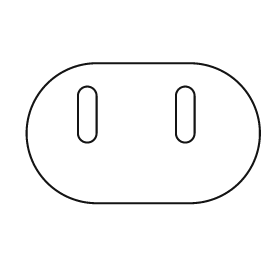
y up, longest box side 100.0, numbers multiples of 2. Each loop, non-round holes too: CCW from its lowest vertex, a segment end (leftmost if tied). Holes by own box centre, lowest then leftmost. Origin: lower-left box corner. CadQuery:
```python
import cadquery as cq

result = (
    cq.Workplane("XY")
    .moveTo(30.0, 0.0)
    .lineTo(70.0, 0.0)
    .threePointArc((100.0, 30.0), (70.0, 60.0))
    .lineTo(30.0, 60.0)
    .threePointArc((0.0, 30.0), (30.0, 0.0))
    .close()
    .moveTo(22.0, 30.0)
    .threePointArc((26.0, 26.0), (30.0, 30.0))
    .lineTo(30.0, 46.0)
    .threePointArc((26.0, 50.0), (22.0, 46.0))
    .close()
    .moveTo(64.0, 30.0)
    .threePointArc((68.0, 26.0), (72.0, 30.0))
    .lineTo(72.0, 46.0)
    .threePointArc((68.0, 50.0), (64.0, 46.0))
    .close()
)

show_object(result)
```